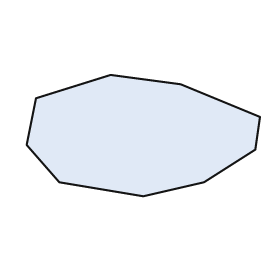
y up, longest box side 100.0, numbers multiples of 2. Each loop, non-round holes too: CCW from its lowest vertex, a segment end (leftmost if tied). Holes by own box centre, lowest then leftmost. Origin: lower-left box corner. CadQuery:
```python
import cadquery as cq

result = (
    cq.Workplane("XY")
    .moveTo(50.0, 0.0)
    .lineTo(76.0, 6.0)
    .lineTo(98.0, 20.0)
    .lineTo(100.0, 34.0)
    .lineTo(66.0, 48.0)
    .lineTo(36.0, 52.0)
    .lineTo(4.0, 42.0)
    .lineTo(0.0, 22.0)
    .lineTo(14.0, 6.0)
    .close()
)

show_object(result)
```